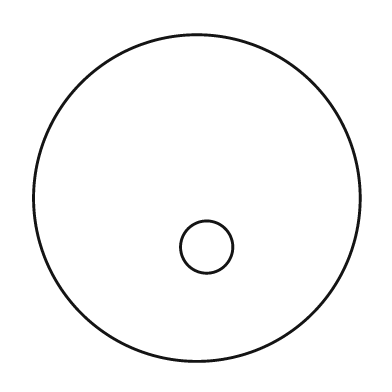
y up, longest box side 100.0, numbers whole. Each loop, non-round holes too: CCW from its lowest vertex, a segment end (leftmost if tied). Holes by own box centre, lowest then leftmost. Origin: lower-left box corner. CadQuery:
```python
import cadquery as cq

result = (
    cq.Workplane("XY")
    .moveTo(50.0, 50.0)
    .circle(50.0)
    .moveTo(53.0, 35.0)
    .circle(8.0)
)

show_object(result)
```